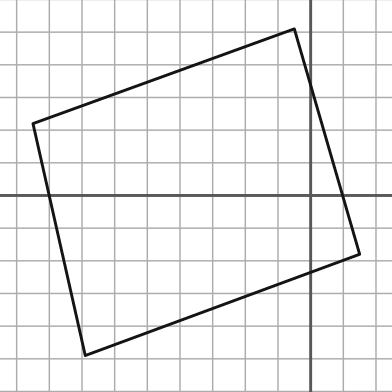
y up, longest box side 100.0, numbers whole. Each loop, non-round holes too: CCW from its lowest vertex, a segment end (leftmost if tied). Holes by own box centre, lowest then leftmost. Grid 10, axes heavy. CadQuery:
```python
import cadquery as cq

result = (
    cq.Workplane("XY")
    .moveTo(-69.0, -49.0)
    .lineTo(15.0, -18.0)
    .lineTo(-5.0, 51.0)
    .lineTo(-85.0, 22.0)
    .close()
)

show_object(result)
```